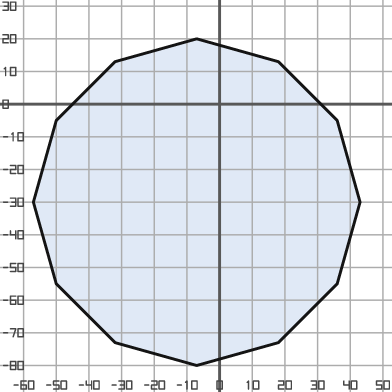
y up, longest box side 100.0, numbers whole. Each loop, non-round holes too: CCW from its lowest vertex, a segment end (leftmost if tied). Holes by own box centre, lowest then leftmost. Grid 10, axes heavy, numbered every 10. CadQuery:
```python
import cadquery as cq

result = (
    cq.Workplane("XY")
    .moveTo(-7.0, -80.0)
    .lineTo(18.0, -73.0)
    .lineTo(36.0, -55.0)
    .lineTo(43.0, -30.0)
    .lineTo(36.0, -5.0)
    .lineTo(18.0, 13.0)
    .lineTo(-7.0, 20.0)
    .lineTo(-32.0, 13.0)
    .lineTo(-50.0, -5.0)
    .lineTo(-57.0, -30.0)
    .lineTo(-50.0, -55.0)
    .lineTo(-32.0, -73.0)
    .close()
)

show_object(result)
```